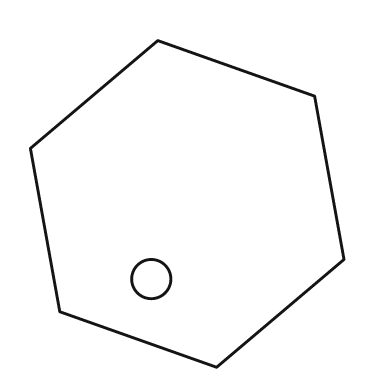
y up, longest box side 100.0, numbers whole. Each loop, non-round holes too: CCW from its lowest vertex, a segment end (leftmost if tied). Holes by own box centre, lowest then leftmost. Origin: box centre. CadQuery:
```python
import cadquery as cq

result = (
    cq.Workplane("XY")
    .moveTo(9.0, -50.0)
    .lineTo(48.0, -17.0)
    .lineTo(39.0, 33.0)
    .lineTo(-9.0, 50.0)
    .lineTo(-48.0, 17.0)
    .lineTo(-39.0, -33.0)
    .close()
    .moveTo(-11.0, -23.0)
    .circle(6.0)
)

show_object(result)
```